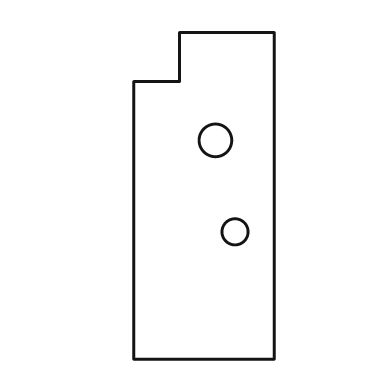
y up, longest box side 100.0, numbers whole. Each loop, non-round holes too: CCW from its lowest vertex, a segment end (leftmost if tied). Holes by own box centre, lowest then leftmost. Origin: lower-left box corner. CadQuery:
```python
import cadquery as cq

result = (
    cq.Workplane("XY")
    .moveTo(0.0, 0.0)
    .lineTo(43.0, 0.0)
    .lineTo(43.0, 100.0)
    .lineTo(14.0, 100.0)
    .lineTo(14.0, 85.0)
    .lineTo(0.0, 85.0)
    .close()
    .moveTo(31.0, 39.0)
    .circle(4.0)
    .moveTo(25.0, 67.0)
    .circle(5.0)
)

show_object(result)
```